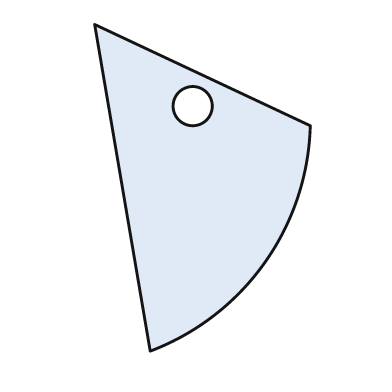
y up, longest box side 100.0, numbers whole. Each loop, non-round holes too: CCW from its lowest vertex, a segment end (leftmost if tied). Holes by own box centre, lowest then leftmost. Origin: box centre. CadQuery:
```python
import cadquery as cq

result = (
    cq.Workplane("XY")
    .moveTo(-16.0, -50.0)
    .threePointArc((19.0, -23.0), (33.0, 19.0))
    .lineTo(-33.0, 50.0)
    .close()
    .moveTo(-3.0, 25.0)
    .circle(6.0)
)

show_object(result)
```